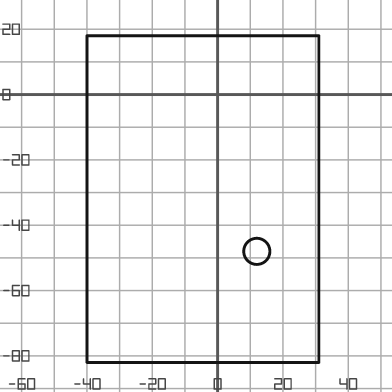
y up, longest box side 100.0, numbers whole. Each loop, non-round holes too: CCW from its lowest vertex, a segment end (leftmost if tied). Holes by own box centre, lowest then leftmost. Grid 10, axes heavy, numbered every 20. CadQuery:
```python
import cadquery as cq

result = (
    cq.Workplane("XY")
    .moveTo(-40.0, -82.0)
    .lineTo(31.0, -82.0)
    .lineTo(31.0, 18.0)
    .lineTo(-40.0, 18.0)
    .close()
    .moveTo(12.0, -48.0)
    .circle(4.0)
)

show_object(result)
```